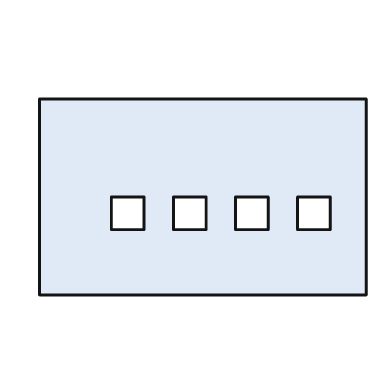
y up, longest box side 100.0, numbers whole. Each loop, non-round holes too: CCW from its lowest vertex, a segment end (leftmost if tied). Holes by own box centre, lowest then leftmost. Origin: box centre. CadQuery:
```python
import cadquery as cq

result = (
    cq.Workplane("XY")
    .moveTo(-50.0, -30.0)
    .lineTo(50.0, -30.0)
    .lineTo(50.0, 30.0)
    .lineTo(-50.0, 30.0)
    .close()
    .moveTo(-28.0, -10.0)
    .lineTo(-18.0, -10.0)
    .lineTo(-18.0, 0.0)
    .lineTo(-28.0, 0.0)
    .close()
    .moveTo(-9.0, -10.0)
    .lineTo(1.0, -10.0)
    .lineTo(1.0, 0.0)
    .lineTo(-9.0, 0.0)
    .close()
    .moveTo(10.0, -10.0)
    .lineTo(20.0, -10.0)
    .lineTo(20.0, 0.0)
    .lineTo(10.0, 0.0)
    .close()
    .moveTo(29.0, -10.0)
    .lineTo(39.0, -10.0)
    .lineTo(39.0, 0.0)
    .lineTo(29.0, 0.0)
    .close()
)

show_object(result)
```